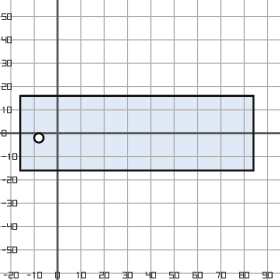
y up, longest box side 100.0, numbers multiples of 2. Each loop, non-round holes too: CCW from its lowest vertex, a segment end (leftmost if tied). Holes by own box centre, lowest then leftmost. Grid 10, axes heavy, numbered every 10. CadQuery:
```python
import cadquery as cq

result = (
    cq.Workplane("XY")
    .moveTo(-16.0, -16.0)
    .lineTo(84.0, -16.0)
    .lineTo(84.0, 16.0)
    .lineTo(-16.0, 16.0)
    .close()
    .moveTo(-8.0, -2.0)
    .circle(2.0)
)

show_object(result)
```